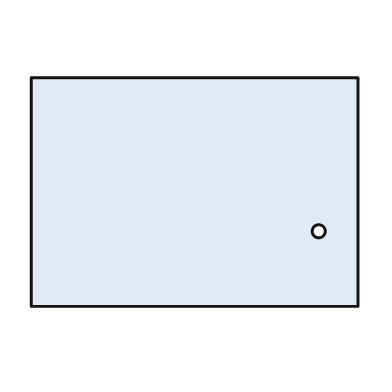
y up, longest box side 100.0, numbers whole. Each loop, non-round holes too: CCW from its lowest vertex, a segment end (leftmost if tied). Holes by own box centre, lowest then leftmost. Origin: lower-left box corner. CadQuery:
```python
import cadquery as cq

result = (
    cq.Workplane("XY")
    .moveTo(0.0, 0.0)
    .lineTo(100.0, 0.0)
    .lineTo(100.0, 70.0)
    .lineTo(0.0, 70.0)
    .close()
    .moveTo(88.0, 23.0)
    .circle(2.0)
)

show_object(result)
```